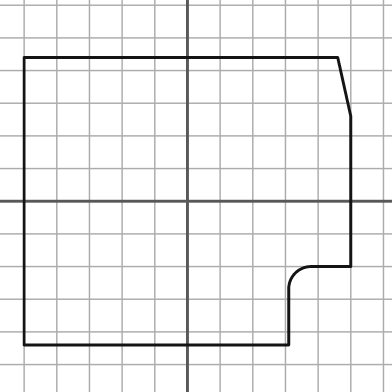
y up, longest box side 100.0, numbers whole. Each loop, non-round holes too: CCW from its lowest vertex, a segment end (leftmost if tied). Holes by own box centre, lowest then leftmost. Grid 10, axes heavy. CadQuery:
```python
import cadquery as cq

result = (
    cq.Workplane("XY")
    .moveTo(-50.0, -44.0)
    .lineTo(31.0, -44.0)
    .lineTo(31.0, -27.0)
    .threePointArc((33.0, -22.0), (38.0, -20.0))
    .lineTo(50.0, -20.0)
    .lineTo(50.0, 26.0)
    .lineTo(46.0, 44.0)
    .lineTo(-50.0, 44.0)
    .close()
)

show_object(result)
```